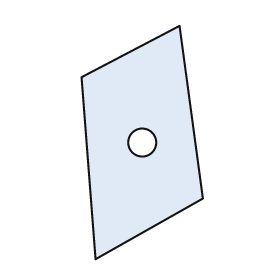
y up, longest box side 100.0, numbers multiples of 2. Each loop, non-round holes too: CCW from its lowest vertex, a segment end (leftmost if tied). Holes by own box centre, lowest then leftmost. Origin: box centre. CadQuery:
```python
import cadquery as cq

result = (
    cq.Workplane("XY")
    .moveTo(-20.0, -50.0)
    .lineTo(26.0, -24.0)
    .lineTo(16.0, 50.0)
    .lineTo(-26.0, 28.0)
    .close()
    .moveTo(0.0, 0.0)
    .circle(6.0)
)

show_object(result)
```